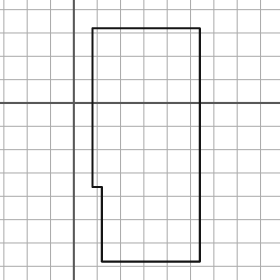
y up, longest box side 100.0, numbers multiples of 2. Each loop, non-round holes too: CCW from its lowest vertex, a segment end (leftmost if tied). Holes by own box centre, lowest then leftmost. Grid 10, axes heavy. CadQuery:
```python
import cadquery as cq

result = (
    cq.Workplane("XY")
    .moveTo(12.0, -68.0)
    .lineTo(54.0, -68.0)
    .lineTo(54.0, 32.0)
    .lineTo(8.0, 32.0)
    .lineTo(8.0, -36.0)
    .lineTo(12.0, -36.0)
    .close()
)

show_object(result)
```